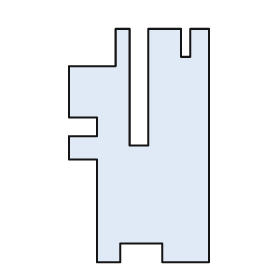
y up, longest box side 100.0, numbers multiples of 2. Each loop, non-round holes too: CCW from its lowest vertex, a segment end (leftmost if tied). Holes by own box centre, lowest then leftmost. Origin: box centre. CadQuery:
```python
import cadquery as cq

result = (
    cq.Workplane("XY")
    .moveTo(-18.0, -50.0)
    .lineTo(-8.0, -50.0)
    .lineTo(-8.0, -42.0)
    .lineTo(10.0, -42.0)
    .lineTo(10.0, -50.0)
    .lineTo(30.0, -50.0)
    .lineTo(30.0, 50.0)
    .lineTo(22.0, 50.0)
    .lineTo(22.0, 38.0)
    .lineTo(18.0, 38.0)
    .lineTo(18.0, 50.0)
    .lineTo(4.0, 50.0)
    .lineTo(4.0, 0.0)
    .lineTo(-4.0, 0.0)
    .lineTo(-4.0, 50.0)
    .lineTo(-10.0, 50.0)
    .lineTo(-10.0, 34.0)
    .lineTo(-30.0, 34.0)
    .lineTo(-30.0, 12.0)
    .lineTo(-18.0, 12.0)
    .lineTo(-18.0, 4.0)
    .lineTo(-30.0, 4.0)
    .lineTo(-30.0, -6.0)
    .lineTo(-18.0, -6.0)
    .close()
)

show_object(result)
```